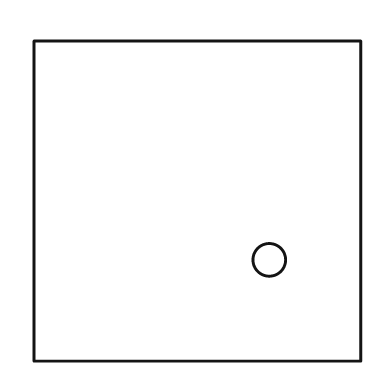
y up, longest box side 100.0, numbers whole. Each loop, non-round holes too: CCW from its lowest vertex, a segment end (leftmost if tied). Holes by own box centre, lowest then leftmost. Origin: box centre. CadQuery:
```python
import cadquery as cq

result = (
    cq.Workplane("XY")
    .moveTo(-50.0, -49.0)
    .lineTo(50.0, -49.0)
    .lineTo(50.0, 49.0)
    .lineTo(-50.0, 49.0)
    .close()
    .moveTo(22.0, -18.0)
    .circle(5.0)
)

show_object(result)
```